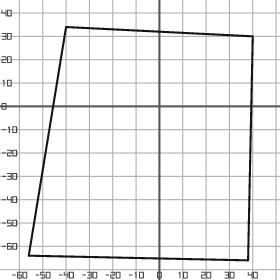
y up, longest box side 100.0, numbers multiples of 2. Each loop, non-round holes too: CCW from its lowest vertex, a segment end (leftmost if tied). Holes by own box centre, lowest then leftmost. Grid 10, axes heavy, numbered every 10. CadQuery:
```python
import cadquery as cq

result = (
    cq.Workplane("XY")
    .moveTo(38.0, -66.0)
    .lineTo(40.0, 30.0)
    .lineTo(-40.0, 34.0)
    .lineTo(-56.0, -64.0)
    .close()
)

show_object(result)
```